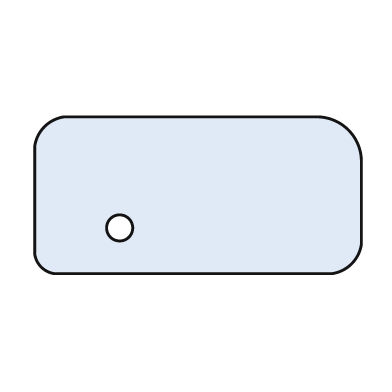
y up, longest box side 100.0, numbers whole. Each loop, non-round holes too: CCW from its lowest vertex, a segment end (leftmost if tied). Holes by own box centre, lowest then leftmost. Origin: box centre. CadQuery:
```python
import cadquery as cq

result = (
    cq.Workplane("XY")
    .moveTo(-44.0, -24.0)
    .lineTo(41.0, -24.0)
    .threePointArc((47.0, -21.0), (50.0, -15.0))
    .lineTo(50.0, 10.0)
    .threePointArc((46.0, 20.0), (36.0, 24.0))
    .lineTo(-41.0, 24.0)
    .threePointArc((-47.0, 21.0), (-50.0, 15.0))
    .lineTo(-50.0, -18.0)
    .threePointArc((-48.0, -22.0), (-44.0, -24.0))
    .close()
    .moveTo(-24.0, -10.0)
    .circle(4.0)
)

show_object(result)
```